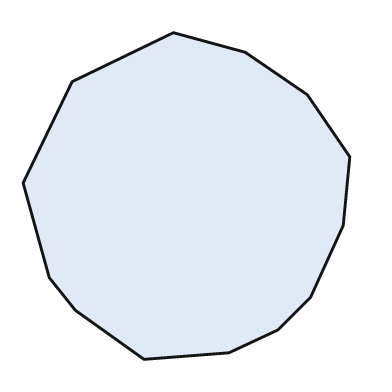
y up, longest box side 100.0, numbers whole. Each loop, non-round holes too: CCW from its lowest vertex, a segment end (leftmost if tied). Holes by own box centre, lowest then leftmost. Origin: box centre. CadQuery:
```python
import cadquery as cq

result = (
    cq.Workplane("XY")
    .moveTo(-13.0, -50.0)
    .lineTo(13.0, -48.0)
    .lineTo(28.0, -41.0)
    .lineTo(38.0, -31.0)
    .lineTo(48.0, -9.0)
    .lineTo(50.0, 12.0)
    .lineTo(37.0, 31.0)
    .lineTo(18.0, 44.0)
    .lineTo(-4.0, 50.0)
    .lineTo(-35.0, 35.0)
    .lineTo(-50.0, 4.0)
    .lineTo(-42.0, -25.0)
    .lineTo(-34.0, -35.0)
    .close()
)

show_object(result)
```